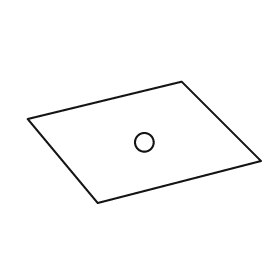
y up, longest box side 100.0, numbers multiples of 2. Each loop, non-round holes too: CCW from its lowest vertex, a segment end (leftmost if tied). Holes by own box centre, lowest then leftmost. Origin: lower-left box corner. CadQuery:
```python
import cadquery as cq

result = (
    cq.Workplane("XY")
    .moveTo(30.0, 0.0)
    .lineTo(100.0, 18.0)
    .lineTo(66.0, 52.0)
    .lineTo(0.0, 36.0)
    .close()
    .moveTo(50.0, 26.0)
    .circle(4.0)
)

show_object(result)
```